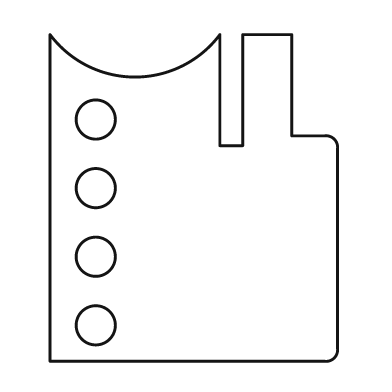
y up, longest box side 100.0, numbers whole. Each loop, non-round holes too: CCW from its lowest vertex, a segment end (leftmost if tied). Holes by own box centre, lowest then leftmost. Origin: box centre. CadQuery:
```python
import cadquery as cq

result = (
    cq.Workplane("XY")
    .moveTo(-44.0, -50.0)
    .lineTo(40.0, -50.0)
    .threePointArc((43.0, -49.0), (44.0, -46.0))
    .lineTo(44.0, 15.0)
    .threePointArc((43.0, 18.0), (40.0, 19.0))
    .lineTo(30.0, 19.0)
    .lineTo(30.0, 50.0)
    .lineTo(15.0, 50.0)
    .lineTo(15.0, 16.0)
    .lineTo(8.0, 16.0)
    .lineTo(8.0, 50.0)
    .threePointArc((-18.0, 37.0), (-44.0, 50.0))
    .close()
    .moveTo(-30.0, -39.0)
    .circle(6.0)
    .moveTo(-30.0, -18.0)
    .circle(6.0)
    .moveTo(-30.0, 3.0)
    .circle(6.0)
    .moveTo(-30.0, 24.0)
    .circle(6.0)
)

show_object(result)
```